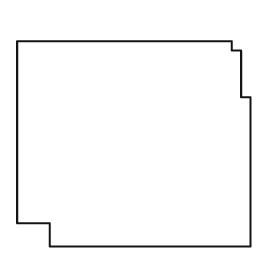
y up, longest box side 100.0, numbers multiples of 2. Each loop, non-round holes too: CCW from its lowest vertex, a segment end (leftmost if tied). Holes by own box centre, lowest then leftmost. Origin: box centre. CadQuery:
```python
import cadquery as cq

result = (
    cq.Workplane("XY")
    .moveTo(-36.0, -44.0)
    .lineTo(50.0, -44.0)
    .lineTo(50.0, 20.0)
    .lineTo(46.0, 20.0)
    .lineTo(46.0, 40.0)
    .lineTo(42.0, 40.0)
    .lineTo(42.0, 44.0)
    .lineTo(-50.0, 44.0)
    .lineTo(-50.0, -34.0)
    .lineTo(-36.0, -34.0)
    .close()
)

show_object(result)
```